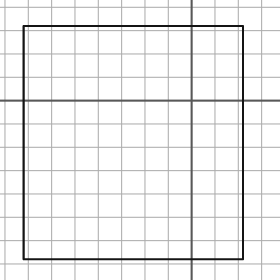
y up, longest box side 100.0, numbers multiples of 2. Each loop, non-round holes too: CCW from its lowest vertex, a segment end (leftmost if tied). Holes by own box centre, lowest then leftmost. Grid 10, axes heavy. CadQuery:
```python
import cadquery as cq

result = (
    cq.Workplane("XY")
    .moveTo(-72.0, -68.0)
    .lineTo(22.0, -68.0)
    .lineTo(22.0, 32.0)
    .lineTo(-72.0, 32.0)
    .close()
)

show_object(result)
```